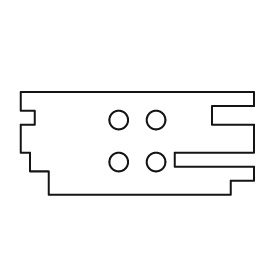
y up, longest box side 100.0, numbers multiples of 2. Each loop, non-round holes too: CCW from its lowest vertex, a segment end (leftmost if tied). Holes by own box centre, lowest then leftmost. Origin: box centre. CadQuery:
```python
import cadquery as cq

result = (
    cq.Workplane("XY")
    .moveTo(-38.0, -22.0)
    .lineTo(40.0, -22.0)
    .lineTo(40.0, -16.0)
    .lineTo(50.0, -16.0)
    .lineTo(50.0, -10.0)
    .lineTo(16.0, -10.0)
    .lineTo(16.0, -4.0)
    .lineTo(50.0, -4.0)
    .lineTo(50.0, 8.0)
    .lineTo(32.0, 8.0)
    .lineTo(32.0, 16.0)
    .lineTo(50.0, 16.0)
    .lineTo(50.0, 22.0)
    .lineTo(-50.0, 22.0)
    .lineTo(-50.0, 14.0)
    .lineTo(-44.0, 14.0)
    .lineTo(-44.0, 8.0)
    .lineTo(-50.0, 8.0)
    .lineTo(-50.0, -4.0)
    .lineTo(-46.0, -4.0)
    .lineTo(-46.0, -12.0)
    .lineTo(-38.0, -12.0)
    .close()
    .moveTo(-8.0, -8.0)
    .circle(4.0)
    .moveTo(8.0, -8.0)
    .circle(4.0)
    .moveTo(-8.0, 10.0)
    .circle(4.0)
    .moveTo(8.0, 10.0)
    .circle(4.0)
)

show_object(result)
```